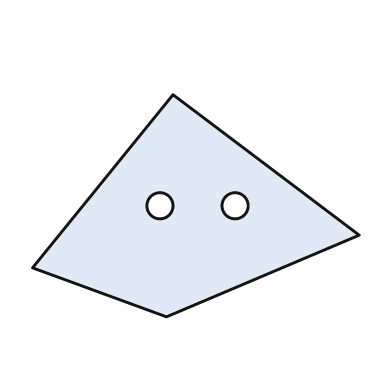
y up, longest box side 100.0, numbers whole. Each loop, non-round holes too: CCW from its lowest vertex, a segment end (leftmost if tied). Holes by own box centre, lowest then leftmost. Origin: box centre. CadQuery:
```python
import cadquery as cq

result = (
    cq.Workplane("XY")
    .moveTo(-9.0, -34.0)
    .lineTo(50.0, -9.0)
    .lineTo(-7.0, 34.0)
    .lineTo(-50.0, -19.0)
    .close()
    .moveTo(-11.0, 0.0)
    .circle(4.0)
    .moveTo(12.0, 0.0)
    .circle(4.0)
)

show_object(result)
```